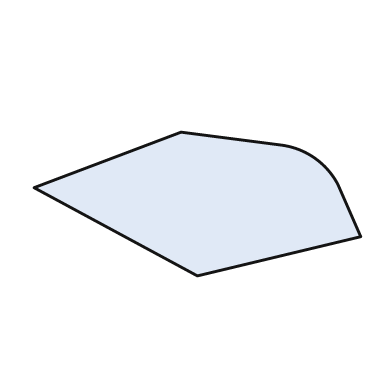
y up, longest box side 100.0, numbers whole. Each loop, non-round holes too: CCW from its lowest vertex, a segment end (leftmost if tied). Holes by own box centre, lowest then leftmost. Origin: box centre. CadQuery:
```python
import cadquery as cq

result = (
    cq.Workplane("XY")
    .moveTo(0.0, -22.0)
    .lineTo(50.0, -10.0)
    .lineTo(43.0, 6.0)
    .threePointArc((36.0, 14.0), (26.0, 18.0))
    .lineTo(-5.0, 22.0)
    .lineTo(-50.0, 5.0)
    .close()
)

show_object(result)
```